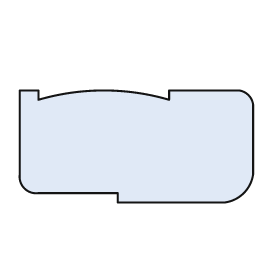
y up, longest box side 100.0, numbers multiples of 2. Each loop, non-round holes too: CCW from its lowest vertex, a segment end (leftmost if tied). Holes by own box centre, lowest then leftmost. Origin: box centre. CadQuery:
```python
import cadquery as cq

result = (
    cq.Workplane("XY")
    .moveTo(-8.0, -24.0)
    .lineTo(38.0, -24.0)
    .threePointArc((46.0, -20.0), (50.0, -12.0))
    .lineTo(50.0, 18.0)
    .threePointArc((48.0, 22.0), (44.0, 24.0))
    .lineTo(14.0, 24.0)
    .lineTo(14.0, 20.0)
    .threePointArc((-14.0, 24.0), (-42.0, 20.0))
    .lineTo(-42.0, 24.0)
    .lineTo(-50.0, 24.0)
    .lineTo(-50.0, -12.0)
    .threePointArc((-48.0, -18.0), (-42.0, -20.0))
    .lineTo(-8.0, -20.0)
    .close()
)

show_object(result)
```